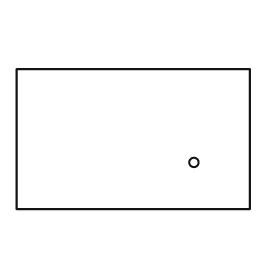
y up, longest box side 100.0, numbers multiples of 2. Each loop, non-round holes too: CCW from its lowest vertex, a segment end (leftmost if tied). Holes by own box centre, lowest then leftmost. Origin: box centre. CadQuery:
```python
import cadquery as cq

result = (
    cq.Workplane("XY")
    .moveTo(-50.0, -30.0)
    .lineTo(50.0, -30.0)
    .lineTo(50.0, 30.0)
    .lineTo(-50.0, 30.0)
    .close()
    .moveTo(26.0, -10.0)
    .circle(2.0)
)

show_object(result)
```